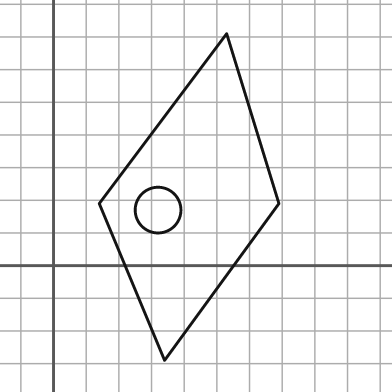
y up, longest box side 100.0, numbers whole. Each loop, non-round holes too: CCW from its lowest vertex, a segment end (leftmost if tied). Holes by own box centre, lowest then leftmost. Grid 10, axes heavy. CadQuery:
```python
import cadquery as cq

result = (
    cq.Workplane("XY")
    .moveTo(34.0, -29.0)
    .lineTo(69.0, 19.0)
    .lineTo(53.0, 71.0)
    .lineTo(14.0, 19.0)
    .close()
    .moveTo(32.0, 17.0)
    .circle(7.0)
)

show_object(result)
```